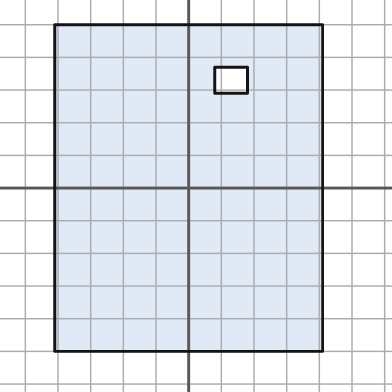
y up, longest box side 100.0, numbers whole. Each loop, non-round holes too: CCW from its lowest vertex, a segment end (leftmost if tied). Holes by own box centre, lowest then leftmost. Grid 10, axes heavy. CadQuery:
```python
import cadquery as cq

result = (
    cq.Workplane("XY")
    .moveTo(-41.0, -50.0)
    .lineTo(41.0, -50.0)
    .lineTo(41.0, 50.0)
    .lineTo(-41.0, 50.0)
    .close()
    .moveTo(8.0, 29.0)
    .lineTo(18.0, 29.0)
    .lineTo(18.0, 37.0)
    .lineTo(8.0, 37.0)
    .close()
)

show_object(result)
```